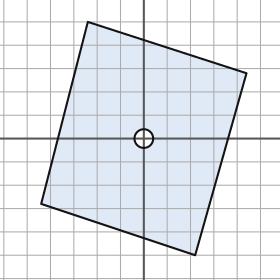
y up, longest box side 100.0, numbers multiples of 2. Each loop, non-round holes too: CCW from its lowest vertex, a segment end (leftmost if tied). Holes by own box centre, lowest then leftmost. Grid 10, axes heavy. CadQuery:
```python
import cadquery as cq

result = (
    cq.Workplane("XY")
    .moveTo(22.0, -50.0)
    .lineTo(44.0, 28.0)
    .lineTo(-24.0, 50.0)
    .lineTo(-44.0, -28.0)
    .close()
    .moveTo(0.0, 0.0)
    .circle(4.0)
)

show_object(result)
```